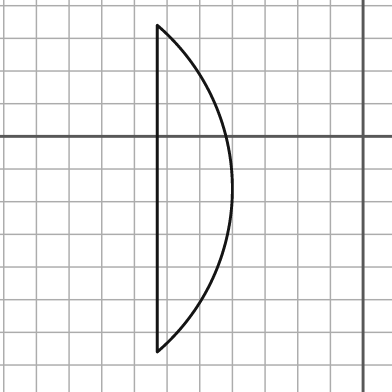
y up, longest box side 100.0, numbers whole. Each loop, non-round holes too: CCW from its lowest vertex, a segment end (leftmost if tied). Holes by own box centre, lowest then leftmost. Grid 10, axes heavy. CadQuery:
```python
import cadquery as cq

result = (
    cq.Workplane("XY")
    .moveTo(-63.0, -66.0)
    .threePointArc((-40.0, -16.0), (-63.0, 34.0))
    .close()
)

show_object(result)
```